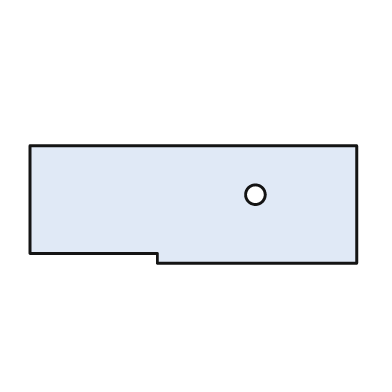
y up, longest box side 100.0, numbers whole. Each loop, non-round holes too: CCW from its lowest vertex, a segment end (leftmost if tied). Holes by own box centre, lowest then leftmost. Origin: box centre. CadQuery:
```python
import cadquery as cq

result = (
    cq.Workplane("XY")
    .moveTo(-11.0, -18.0)
    .lineTo(50.0, -18.0)
    .lineTo(50.0, 18.0)
    .lineTo(-50.0, 18.0)
    .lineTo(-50.0, -15.0)
    .lineTo(-11.0, -15.0)
    .close()
    .moveTo(19.0, 3.0)
    .circle(3.0)
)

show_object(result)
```